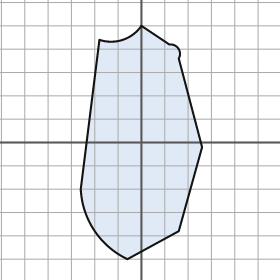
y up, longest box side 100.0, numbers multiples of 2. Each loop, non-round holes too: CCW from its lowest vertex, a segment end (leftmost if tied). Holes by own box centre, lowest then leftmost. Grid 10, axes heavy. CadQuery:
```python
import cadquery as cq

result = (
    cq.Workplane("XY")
    .moveTo(-6.0, -50.0)
    .lineTo(16.0, -38.0)
    .lineTo(26.0, -2.0)
    .lineTo(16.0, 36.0)
    .threePointArc((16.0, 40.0), (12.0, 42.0))
    .lineTo(0.0, 50.0)
    .threePointArc((-8.0, 44.0), (-18.0, 44.0))
    .lineTo(-26.0, -20.0)
    .threePointArc((-20.0, -38.0), (-6.0, -50.0))
    .close()
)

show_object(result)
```